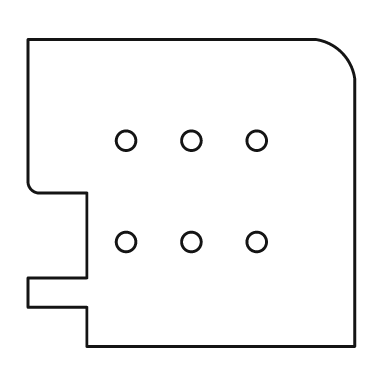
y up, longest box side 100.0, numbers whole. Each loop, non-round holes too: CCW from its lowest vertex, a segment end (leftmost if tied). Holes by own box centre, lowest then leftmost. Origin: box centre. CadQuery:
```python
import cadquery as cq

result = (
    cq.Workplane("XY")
    .moveTo(-32.0, -47.0)
    .lineTo(50.0, -47.0)
    .lineTo(50.0, 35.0)
    .threePointArc((46.0, 43.0), (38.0, 47.0))
    .lineTo(-50.0, 47.0)
    .lineTo(-50.0, 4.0)
    .threePointArc((-49.0, 1.0), (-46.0, 0.0))
    .lineTo(-32.0, 0.0)
    .lineTo(-32.0, -26.0)
    .lineTo(-50.0, -26.0)
    .lineTo(-50.0, -35.0)
    .lineTo(-32.0, -35.0)
    .close()
    .moveTo(-20.0, -15.0)
    .circle(3.0)
    .moveTo(0.0, -15.0)
    .circle(3.0)
    .moveTo(20.0, -15.0)
    .circle(3.0)
    .moveTo(-20.0, 16.0)
    .circle(3.0)
    .moveTo(0.0, 16.0)
    .circle(3.0)
    .moveTo(20.0, 16.0)
    .circle(3.0)
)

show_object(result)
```